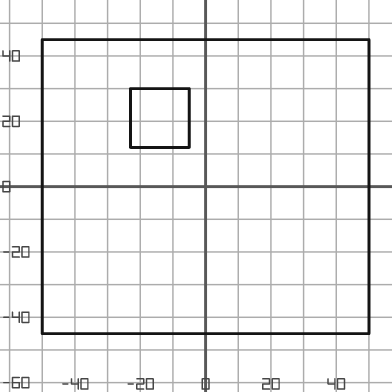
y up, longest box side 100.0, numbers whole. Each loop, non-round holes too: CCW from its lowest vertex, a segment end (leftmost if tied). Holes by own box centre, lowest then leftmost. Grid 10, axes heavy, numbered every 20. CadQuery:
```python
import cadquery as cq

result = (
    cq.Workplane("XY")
    .moveTo(-50.0, -45.0)
    .lineTo(50.0, -45.0)
    .lineTo(50.0, 45.0)
    .lineTo(-50.0, 45.0)
    .close()
    .moveTo(-23.0, 12.0)
    .lineTo(-5.0, 12.0)
    .lineTo(-5.0, 30.0)
    .lineTo(-23.0, 30.0)
    .close()
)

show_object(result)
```